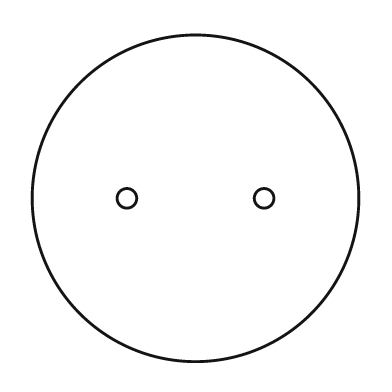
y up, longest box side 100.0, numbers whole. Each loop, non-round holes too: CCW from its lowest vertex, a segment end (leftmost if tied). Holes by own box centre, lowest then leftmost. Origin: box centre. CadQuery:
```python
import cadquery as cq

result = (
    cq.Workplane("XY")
    .moveTo(0.0, 0.0)
    .circle(50.0)
    .moveTo(-21.0, 0.0)
    .circle(3.0)
    .moveTo(21.0, 0.0)
    .circle(3.0)
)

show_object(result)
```